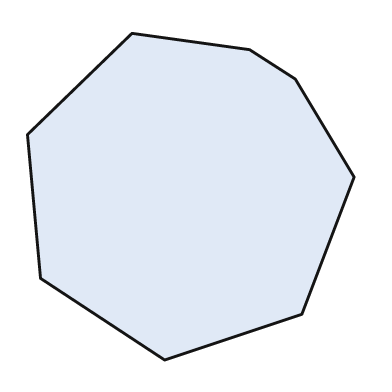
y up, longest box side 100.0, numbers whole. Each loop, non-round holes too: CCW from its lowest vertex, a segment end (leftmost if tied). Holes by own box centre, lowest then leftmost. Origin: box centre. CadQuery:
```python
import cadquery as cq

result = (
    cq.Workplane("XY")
    .moveTo(-8.0, -50.0)
    .lineTo(34.0, -36.0)
    .lineTo(50.0, 6.0)
    .lineTo(32.0, 36.0)
    .lineTo(18.0, 45.0)
    .lineTo(-18.0, 50.0)
    .lineTo(-50.0, 19.0)
    .lineTo(-46.0, -25.0)
    .close()
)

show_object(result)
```